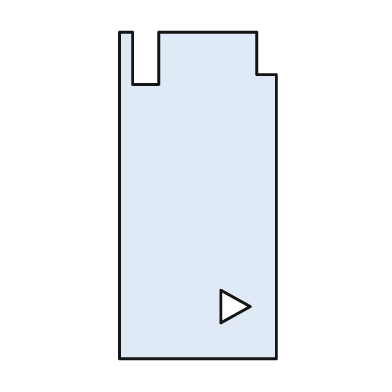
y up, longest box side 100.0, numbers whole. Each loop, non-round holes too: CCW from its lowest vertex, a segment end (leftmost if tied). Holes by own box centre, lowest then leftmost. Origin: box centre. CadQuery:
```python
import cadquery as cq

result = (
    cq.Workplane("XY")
    .moveTo(-24.0, -50.0)
    .lineTo(24.0, -50.0)
    .lineTo(24.0, 37.0)
    .lineTo(18.0, 37.0)
    .lineTo(18.0, 50.0)
    .lineTo(-12.0, 50.0)
    .lineTo(-12.0, 34.0)
    .lineTo(-20.0, 34.0)
    .lineTo(-20.0, 50.0)
    .lineTo(-24.0, 50.0)
    .close()
    .moveTo(7.0, -39.0)
    .lineTo(16.0, -34.0)
    .lineTo(7.0, -29.0)
    .close()
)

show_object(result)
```